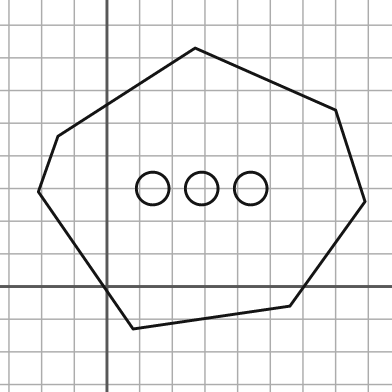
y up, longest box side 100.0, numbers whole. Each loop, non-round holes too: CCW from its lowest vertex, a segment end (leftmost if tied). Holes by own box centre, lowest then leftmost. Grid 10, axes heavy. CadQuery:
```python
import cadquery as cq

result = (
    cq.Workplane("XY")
    .moveTo(8.0, -13.0)
    .lineTo(56.0, -6.0)
    .lineTo(79.0, 26.0)
    .lineTo(70.0, 54.0)
    .lineTo(27.0, 73.0)
    .lineTo(-15.0, 46.0)
    .lineTo(-21.0, 29.0)
    .close()
    .moveTo(14.0, 30.0)
    .circle(5.0)
    .moveTo(29.0, 30.0)
    .circle(5.0)
    .moveTo(44.0, 30.0)
    .circle(5.0)
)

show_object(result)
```